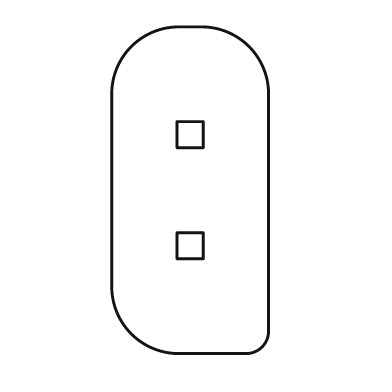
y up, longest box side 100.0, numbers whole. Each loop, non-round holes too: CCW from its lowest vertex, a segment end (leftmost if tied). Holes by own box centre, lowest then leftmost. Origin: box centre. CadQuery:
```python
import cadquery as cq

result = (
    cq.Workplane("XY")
    .moveTo(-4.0, -50.0)
    .lineTo(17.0, -50.0)
    .threePointArc((22.0, -48.0), (24.0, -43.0))
    .lineTo(24.0, 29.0)
    .threePointArc((18.0, 44.0), (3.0, 50.0))
    .lineTo(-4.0, 50.0)
    .threePointArc((-18.0, 44.0), (-24.0, 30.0))
    .lineTo(-24.0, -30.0)
    .threePointArc((-18.0, -44.0), (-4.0, -50.0))
    .close()
    .moveTo(-4.0, -21.0)
    .lineTo(4.0, -21.0)
    .lineTo(4.0, -13.0)
    .lineTo(-4.0, -13.0)
    .close()
    .moveTo(-4.0, 13.0)
    .lineTo(4.0, 13.0)
    .lineTo(4.0, 21.0)
    .lineTo(-4.0, 21.0)
    .close()
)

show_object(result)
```